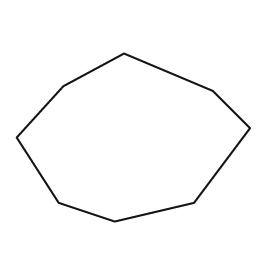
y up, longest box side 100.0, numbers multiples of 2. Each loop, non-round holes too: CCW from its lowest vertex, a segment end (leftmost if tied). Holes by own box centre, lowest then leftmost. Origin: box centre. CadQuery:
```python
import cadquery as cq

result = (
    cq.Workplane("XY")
    .moveTo(-8.0, -36.0)
    .lineTo(26.0, -28.0)
    .lineTo(50.0, 4.0)
    .lineTo(34.0, 20.0)
    .lineTo(-4.0, 36.0)
    .lineTo(-30.0, 22.0)
    .lineTo(-50.0, 0.0)
    .lineTo(-32.0, -28.0)
    .close()
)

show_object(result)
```